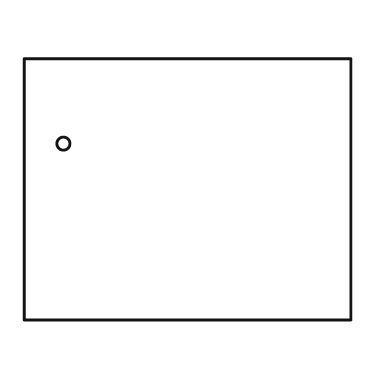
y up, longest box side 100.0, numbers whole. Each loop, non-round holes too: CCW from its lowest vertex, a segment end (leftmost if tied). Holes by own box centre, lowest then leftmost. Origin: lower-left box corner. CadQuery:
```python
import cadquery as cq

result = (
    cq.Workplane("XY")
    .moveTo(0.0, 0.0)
    .lineTo(100.0, 0.0)
    .lineTo(100.0, 80.0)
    .lineTo(0.0, 80.0)
    .close()
    .moveTo(12.0, 54.0)
    .circle(2.0)
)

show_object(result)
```